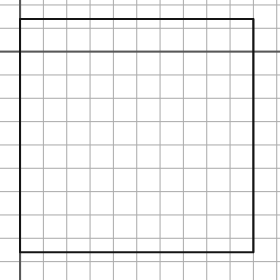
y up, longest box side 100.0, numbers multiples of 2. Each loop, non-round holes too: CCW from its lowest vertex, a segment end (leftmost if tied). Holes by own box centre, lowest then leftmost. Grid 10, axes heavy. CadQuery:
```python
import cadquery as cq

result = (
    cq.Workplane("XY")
    .moveTo(0.0, -86.0)
    .lineTo(100.0, -86.0)
    .lineTo(100.0, 14.0)
    .lineTo(0.0, 14.0)
    .close()
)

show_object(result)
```